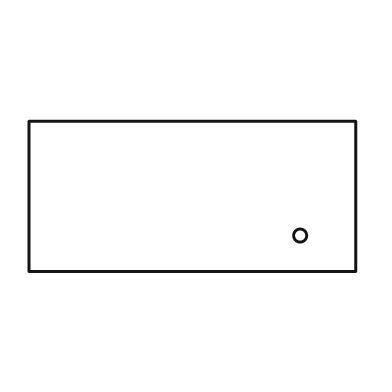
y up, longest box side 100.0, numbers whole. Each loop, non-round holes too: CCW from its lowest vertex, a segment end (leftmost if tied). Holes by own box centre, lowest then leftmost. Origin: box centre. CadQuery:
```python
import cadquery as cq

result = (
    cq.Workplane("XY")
    .moveTo(-50.0, -23.0)
    .lineTo(50.0, -23.0)
    .lineTo(50.0, 23.0)
    .lineTo(-50.0, 23.0)
    .close()
    .moveTo(33.0, -12.0)
    .circle(2.0)
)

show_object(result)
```